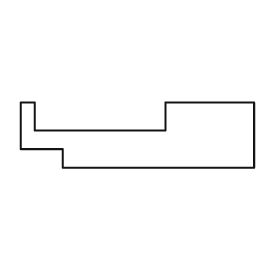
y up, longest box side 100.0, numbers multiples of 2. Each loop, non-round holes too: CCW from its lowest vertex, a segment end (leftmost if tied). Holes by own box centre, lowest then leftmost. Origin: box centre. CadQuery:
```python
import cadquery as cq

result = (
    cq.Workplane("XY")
    .moveTo(-32.0, -14.0)
    .lineTo(50.0, -14.0)
    .lineTo(50.0, 14.0)
    .lineTo(12.0, 14.0)
    .lineTo(12.0, 2.0)
    .lineTo(-44.0, 2.0)
    .lineTo(-44.0, 14.0)
    .lineTo(-50.0, 14.0)
    .lineTo(-50.0, -6.0)
    .lineTo(-32.0, -6.0)
    .close()
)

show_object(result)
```